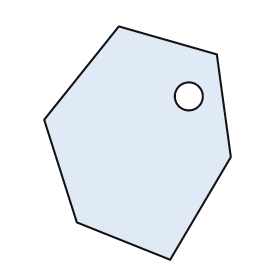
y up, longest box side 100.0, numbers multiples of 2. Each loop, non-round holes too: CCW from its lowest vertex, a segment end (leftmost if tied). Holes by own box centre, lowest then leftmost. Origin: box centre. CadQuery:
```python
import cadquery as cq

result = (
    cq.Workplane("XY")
    .moveTo(14.0, -50.0)
    .lineTo(40.0, -6.0)
    .lineTo(34.0, 38.0)
    .lineTo(-8.0, 50.0)
    .lineTo(-40.0, 10.0)
    .lineTo(-26.0, -34.0)
    .close()
    .moveTo(22.0, 20.0)
    .circle(6.0)
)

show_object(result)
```